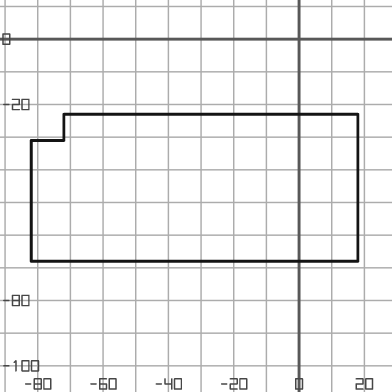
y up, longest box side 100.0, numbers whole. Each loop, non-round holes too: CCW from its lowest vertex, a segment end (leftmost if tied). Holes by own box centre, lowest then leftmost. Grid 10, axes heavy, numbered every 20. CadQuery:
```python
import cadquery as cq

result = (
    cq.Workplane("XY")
    .moveTo(-82.0, -68.0)
    .lineTo(18.0, -68.0)
    .lineTo(18.0, -23.0)
    .lineTo(-72.0, -23.0)
    .lineTo(-72.0, -31.0)
    .lineTo(-82.0, -31.0)
    .close()
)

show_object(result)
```